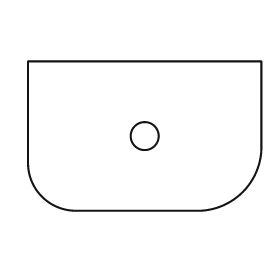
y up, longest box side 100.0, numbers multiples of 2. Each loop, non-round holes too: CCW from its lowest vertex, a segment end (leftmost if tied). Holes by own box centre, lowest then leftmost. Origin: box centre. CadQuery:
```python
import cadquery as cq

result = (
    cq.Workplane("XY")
    .moveTo(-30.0, -32.0)
    .lineTo(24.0, -32.0)
    .threePointArc((42.0, -24.0), (50.0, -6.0))
    .lineTo(50.0, 32.0)
    .lineTo(-50.0, 32.0)
    .lineTo(-50.0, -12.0)
    .threePointArc((-44.0, -26.0), (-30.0, -32.0))
    .close()
    .moveTo(0.0, 0.0)
    .circle(6.0)
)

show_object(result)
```